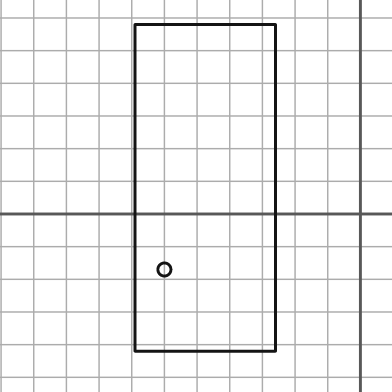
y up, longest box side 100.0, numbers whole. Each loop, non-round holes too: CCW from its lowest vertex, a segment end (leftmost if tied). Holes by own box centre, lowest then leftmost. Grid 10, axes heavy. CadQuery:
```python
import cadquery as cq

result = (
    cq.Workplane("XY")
    .moveTo(-69.0, -42.0)
    .lineTo(-26.0, -42.0)
    .lineTo(-26.0, 58.0)
    .lineTo(-69.0, 58.0)
    .close()
    .moveTo(-60.0, -17.0)
    .circle(2.0)
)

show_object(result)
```